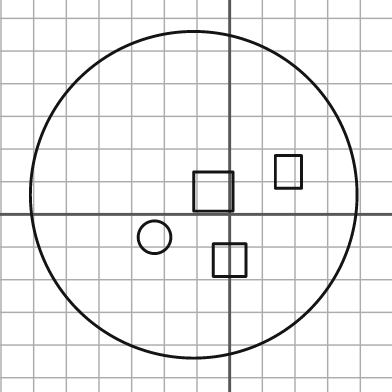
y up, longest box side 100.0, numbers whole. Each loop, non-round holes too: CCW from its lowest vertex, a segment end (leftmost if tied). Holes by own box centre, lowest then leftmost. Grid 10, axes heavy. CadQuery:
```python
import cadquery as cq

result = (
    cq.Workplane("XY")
    .moveTo(-11.0, 6.0)
    .circle(50.0)
    .moveTo(-5.0, -19.0)
    .lineTo(5.0, -19.0)
    .lineTo(5.0, -9.0)
    .lineTo(-5.0, -9.0)
    .close()
    .moveTo(-23.0, -7.0)
    .circle(5.0)
    .moveTo(-11.0, 1.0)
    .lineTo(1.0, 1.0)
    .lineTo(1.0, 13.0)
    .lineTo(-11.0, 13.0)
    .close()
    .moveTo(14.0, 8.0)
    .lineTo(22.0, 8.0)
    .lineTo(22.0, 18.0)
    .lineTo(14.0, 18.0)
    .close()
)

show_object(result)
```